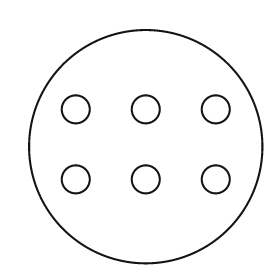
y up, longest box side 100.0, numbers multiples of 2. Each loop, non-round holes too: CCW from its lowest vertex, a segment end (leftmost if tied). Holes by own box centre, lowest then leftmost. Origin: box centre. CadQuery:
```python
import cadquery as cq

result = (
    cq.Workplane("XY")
    .moveTo(0.0, 0.0)
    .circle(50.0)
    .moveTo(-30.0, -14.0)
    .circle(6.0)
    .moveTo(0.0, -14.0)
    .circle(6.0)
    .moveTo(30.0, -14.0)
    .circle(6.0)
    .moveTo(-30.0, 16.0)
    .circle(6.0)
    .moveTo(0.0, 16.0)
    .circle(6.0)
    .moveTo(30.0, 16.0)
    .circle(6.0)
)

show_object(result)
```